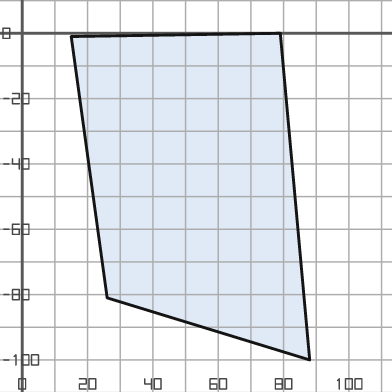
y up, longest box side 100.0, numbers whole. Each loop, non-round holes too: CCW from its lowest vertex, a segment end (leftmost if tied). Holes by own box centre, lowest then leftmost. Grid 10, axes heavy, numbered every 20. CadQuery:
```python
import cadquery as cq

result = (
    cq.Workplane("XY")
    .moveTo(88.0, -100.0)
    .lineTo(79.0, 0.0)
    .lineTo(15.0, -1.0)
    .lineTo(26.0, -81.0)
    .close()
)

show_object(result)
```